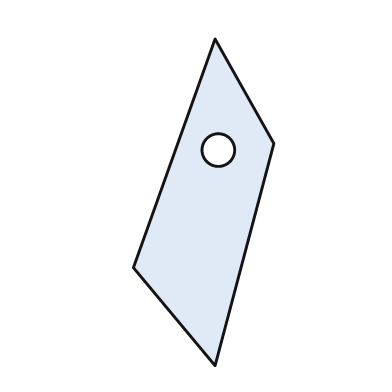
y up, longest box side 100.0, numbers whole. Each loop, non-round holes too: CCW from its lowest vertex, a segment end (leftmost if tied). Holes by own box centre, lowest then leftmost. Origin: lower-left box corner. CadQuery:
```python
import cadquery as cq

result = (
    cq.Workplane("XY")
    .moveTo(25.0, 0.0)
    .lineTo(43.0, 68.0)
    .lineTo(25.0, 100.0)
    .lineTo(0.0, 30.0)
    .close()
    .moveTo(26.0, 66.0)
    .circle(5.0)
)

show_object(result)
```